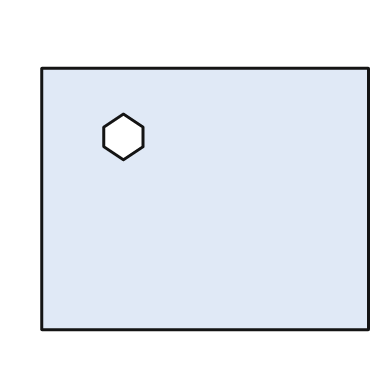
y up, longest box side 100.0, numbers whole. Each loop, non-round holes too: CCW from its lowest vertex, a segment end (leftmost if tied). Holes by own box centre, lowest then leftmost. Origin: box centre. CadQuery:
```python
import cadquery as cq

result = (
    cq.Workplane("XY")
    .moveTo(-50.0, -40.0)
    .lineTo(50.0, -40.0)
    .lineTo(50.0, 40.0)
    .lineTo(-50.0, 40.0)
    .close()
    .moveTo(-25.0, 12.0)
    .lineTo(-19.0, 16.0)
    .lineTo(-19.0, 22.0)
    .lineTo(-25.0, 26.0)
    .lineTo(-31.0, 22.0)
    .lineTo(-31.0, 16.0)
    .close()
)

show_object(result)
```